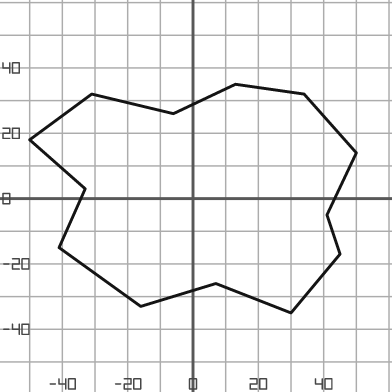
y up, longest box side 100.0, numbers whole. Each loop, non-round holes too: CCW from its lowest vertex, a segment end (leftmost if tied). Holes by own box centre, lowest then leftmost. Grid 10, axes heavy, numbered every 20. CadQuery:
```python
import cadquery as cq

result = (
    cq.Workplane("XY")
    .moveTo(30.0, -35.0)
    .lineTo(45.0, -17.0)
    .lineTo(41.0, -5.0)
    .lineTo(50.0, 14.0)
    .lineTo(34.0, 32.0)
    .lineTo(13.0, 35.0)
    .lineTo(-6.0, 26.0)
    .lineTo(-31.0, 32.0)
    .lineTo(-50.0, 18.0)
    .lineTo(-33.0, 3.0)
    .lineTo(-41.0, -15.0)
    .lineTo(-16.0, -33.0)
    .lineTo(7.0, -26.0)
    .close()
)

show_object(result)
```